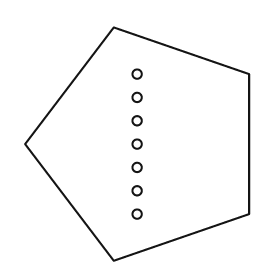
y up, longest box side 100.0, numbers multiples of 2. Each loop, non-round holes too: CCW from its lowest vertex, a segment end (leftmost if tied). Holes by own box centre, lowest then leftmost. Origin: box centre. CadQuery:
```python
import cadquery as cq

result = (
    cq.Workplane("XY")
    .moveTo(-10.0, -50.0)
    .lineTo(48.0, -30.0)
    .lineTo(48.0, 30.0)
    .lineTo(-10.0, 50.0)
    .lineTo(-48.0, 0.0)
    .close()
    .moveTo(0.0, -30.0)
    .circle(2.0)
    .moveTo(0.0, -20.0)
    .circle(2.0)
    .moveTo(0.0, -10.0)
    .circle(2.0)
    .moveTo(0.0, 0.0)
    .circle(2.0)
    .moveTo(0.0, 10.0)
    .circle(2.0)
    .moveTo(0.0, 20.0)
    .circle(2.0)
    .moveTo(0.0, 30.0)
    .circle(2.0)
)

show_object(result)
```